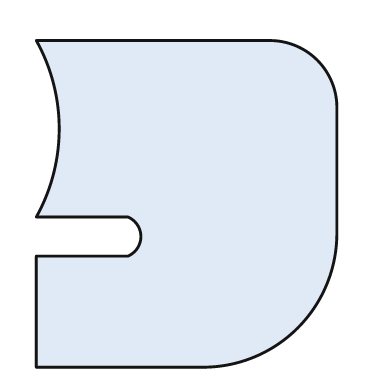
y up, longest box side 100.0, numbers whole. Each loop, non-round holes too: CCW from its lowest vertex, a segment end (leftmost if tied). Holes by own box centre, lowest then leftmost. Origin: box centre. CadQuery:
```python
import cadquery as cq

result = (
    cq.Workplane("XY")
    .moveTo(-46.0, -50.0)
    .lineTo(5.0, -50.0)
    .threePointArc((34.0, -38.0), (46.0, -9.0))
    .lineTo(46.0, 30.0)
    .threePointArc((40.0, 44.0), (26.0, 50.0))
    .lineTo(-46.0, 50.0)
    .threePointArc((-39.0, 23.0), (-46.0, -4.0))
    .lineTo(-18.0, -4.0)
    .threePointArc((-14.0, -10.0), (-18.0, -16.0))
    .lineTo(-46.0, -16.0)
    .close()
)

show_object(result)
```